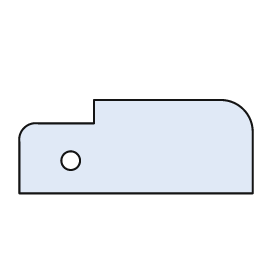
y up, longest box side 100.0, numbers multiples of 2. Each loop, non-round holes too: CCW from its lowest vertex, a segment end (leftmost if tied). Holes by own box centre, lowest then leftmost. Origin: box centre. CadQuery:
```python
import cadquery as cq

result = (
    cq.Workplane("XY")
    .moveTo(-50.0, -20.0)
    .lineTo(50.0, -20.0)
    .lineTo(50.0, 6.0)
    .threePointArc((46.0, 16.0), (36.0, 20.0))
    .lineTo(-18.0, 20.0)
    .lineTo(-18.0, 10.0)
    .lineTo(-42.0, 10.0)
    .threePointArc((-48.0, 8.0), (-50.0, 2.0))
    .close()
    .moveTo(-28.0, -6.0)
    .circle(4.0)
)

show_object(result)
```